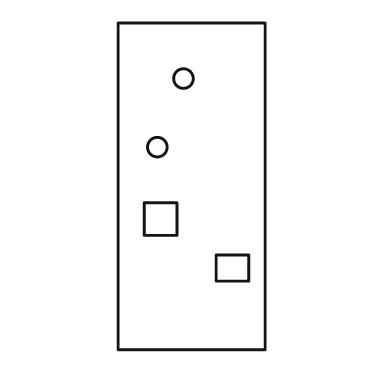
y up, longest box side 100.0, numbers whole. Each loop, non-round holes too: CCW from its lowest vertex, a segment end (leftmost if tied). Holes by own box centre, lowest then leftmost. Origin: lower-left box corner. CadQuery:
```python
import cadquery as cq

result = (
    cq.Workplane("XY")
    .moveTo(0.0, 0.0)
    .lineTo(45.0, 0.0)
    .lineTo(45.0, 100.0)
    .lineTo(0.0, 100.0)
    .close()
    .moveTo(30.0, 21.0)
    .lineTo(40.0, 21.0)
    .lineTo(40.0, 29.0)
    .lineTo(30.0, 29.0)
    .close()
    .moveTo(8.0, 35.0)
    .lineTo(18.0, 35.0)
    .lineTo(18.0, 45.0)
    .lineTo(8.0, 45.0)
    .close()
    .moveTo(12.0, 62.0)
    .circle(3.0)
    .moveTo(20.0, 83.0)
    .circle(3.0)
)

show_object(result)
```